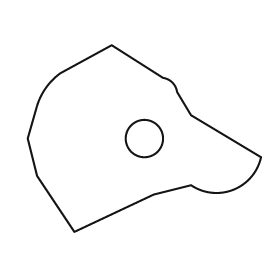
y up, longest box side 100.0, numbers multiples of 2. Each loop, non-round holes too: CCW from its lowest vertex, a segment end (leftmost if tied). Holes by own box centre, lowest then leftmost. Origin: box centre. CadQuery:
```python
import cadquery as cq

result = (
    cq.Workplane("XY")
    .moveTo(-30.0, -40.0)
    .lineTo(4.0, -24.0)
    .lineTo(20.0, -20.0)
    .threePointArc((38.0, -22.0), (50.0, -8.0))
    .lineTo(20.0, 10.0)
    .lineTo(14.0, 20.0)
    .threePointArc((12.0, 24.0), (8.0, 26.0))
    .lineTo(-14.0, 40.0)
    .lineTo(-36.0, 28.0)
    .threePointArc((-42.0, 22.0), (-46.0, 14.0))
    .lineTo(-50.0, 0.0)
    .lineTo(-46.0, -16.0)
    .close()
    .moveTo(0.0, 0.0)
    .circle(8.0)
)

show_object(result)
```